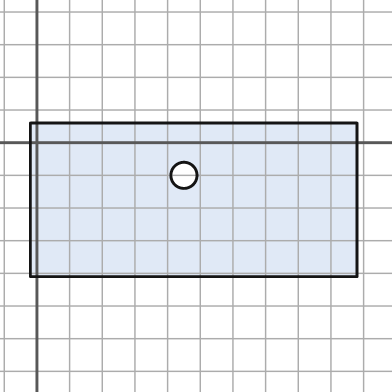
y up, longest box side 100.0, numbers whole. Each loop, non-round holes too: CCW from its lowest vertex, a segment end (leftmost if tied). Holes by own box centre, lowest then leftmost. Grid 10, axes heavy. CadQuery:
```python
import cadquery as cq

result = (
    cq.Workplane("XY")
    .moveTo(-2.0, -41.0)
    .lineTo(98.0, -41.0)
    .lineTo(98.0, 6.0)
    .lineTo(-2.0, 6.0)
    .close()
    .moveTo(45.0, -10.0)
    .circle(4.0)
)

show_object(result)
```